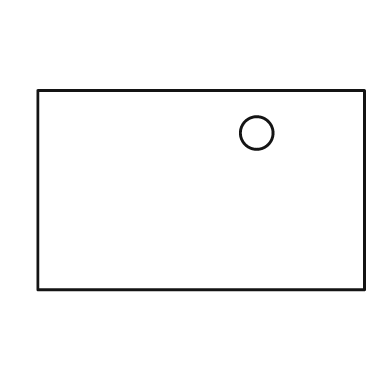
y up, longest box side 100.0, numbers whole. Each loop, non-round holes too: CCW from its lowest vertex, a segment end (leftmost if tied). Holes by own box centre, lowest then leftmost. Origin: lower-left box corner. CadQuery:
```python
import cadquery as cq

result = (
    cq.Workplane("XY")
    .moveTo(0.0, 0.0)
    .lineTo(100.0, 0.0)
    .lineTo(100.0, 61.0)
    .lineTo(0.0, 61.0)
    .close()
    .moveTo(67.0, 48.0)
    .circle(5.0)
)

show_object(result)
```